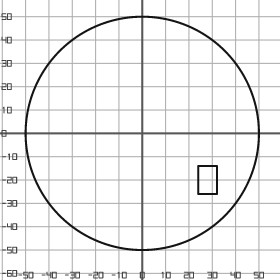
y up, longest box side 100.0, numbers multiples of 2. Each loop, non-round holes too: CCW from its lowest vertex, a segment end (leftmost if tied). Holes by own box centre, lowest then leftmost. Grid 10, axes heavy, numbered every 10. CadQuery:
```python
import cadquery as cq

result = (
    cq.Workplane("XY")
    .moveTo(0.0, 0.0)
    .circle(50.0)
    .moveTo(24.0, -26.0)
    .lineTo(32.0, -26.0)
    .lineTo(32.0, -14.0)
    .lineTo(24.0, -14.0)
    .close()
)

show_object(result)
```